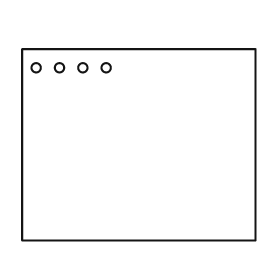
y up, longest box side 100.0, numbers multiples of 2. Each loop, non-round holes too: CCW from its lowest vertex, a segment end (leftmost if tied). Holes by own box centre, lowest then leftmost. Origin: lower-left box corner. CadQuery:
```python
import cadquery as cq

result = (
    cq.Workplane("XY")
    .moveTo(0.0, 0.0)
    .lineTo(100.0, 0.0)
    .lineTo(100.0, 82.0)
    .lineTo(0.0, 82.0)
    .close()
    .moveTo(6.0, 74.0)
    .circle(2.0)
    .moveTo(16.0, 74.0)
    .circle(2.0)
    .moveTo(26.0, 74.0)
    .circle(2.0)
    .moveTo(36.0, 74.0)
    .circle(2.0)
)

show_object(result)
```